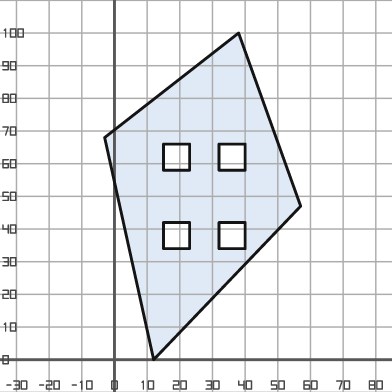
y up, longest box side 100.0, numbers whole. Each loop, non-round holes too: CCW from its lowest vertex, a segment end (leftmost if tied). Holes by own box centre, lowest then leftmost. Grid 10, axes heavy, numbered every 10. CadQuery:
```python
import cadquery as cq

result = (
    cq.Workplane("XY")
    .moveTo(12.0, 0.0)
    .lineTo(57.0, 47.0)
    .lineTo(38.0, 100.0)
    .lineTo(-3.0, 68.0)
    .close()
    .moveTo(15.0, 34.0)
    .lineTo(23.0, 34.0)
    .lineTo(23.0, 42.0)
    .lineTo(15.0, 42.0)
    .close()
    .moveTo(32.0, 34.0)
    .lineTo(40.0, 34.0)
    .lineTo(40.0, 42.0)
    .lineTo(32.0, 42.0)
    .close()
    .moveTo(15.0, 58.0)
    .lineTo(23.0, 58.0)
    .lineTo(23.0, 66.0)
    .lineTo(15.0, 66.0)
    .close()
    .moveTo(32.0, 58.0)
    .lineTo(40.0, 58.0)
    .lineTo(40.0, 66.0)
    .lineTo(32.0, 66.0)
    .close()
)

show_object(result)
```